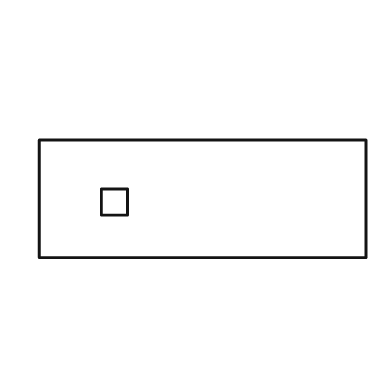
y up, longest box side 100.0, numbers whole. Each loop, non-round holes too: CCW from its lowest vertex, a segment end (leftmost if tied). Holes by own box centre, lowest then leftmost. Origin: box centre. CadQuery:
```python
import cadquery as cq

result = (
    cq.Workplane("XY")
    .moveTo(-50.0, -18.0)
    .lineTo(50.0, -18.0)
    .lineTo(50.0, 18.0)
    .lineTo(-50.0, 18.0)
    .close()
    .moveTo(-31.0, -5.0)
    .lineTo(-23.0, -5.0)
    .lineTo(-23.0, 3.0)
    .lineTo(-31.0, 3.0)
    .close()
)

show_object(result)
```